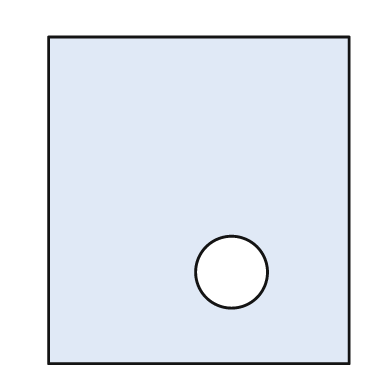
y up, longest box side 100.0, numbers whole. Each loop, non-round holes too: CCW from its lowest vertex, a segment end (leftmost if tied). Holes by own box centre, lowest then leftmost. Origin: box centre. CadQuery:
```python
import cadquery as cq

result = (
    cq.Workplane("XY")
    .moveTo(-46.0, -50.0)
    .lineTo(46.0, -50.0)
    .lineTo(46.0, 50.0)
    .lineTo(-46.0, 50.0)
    .close()
    .moveTo(10.0, -22.0)
    .circle(11.0)
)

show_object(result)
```